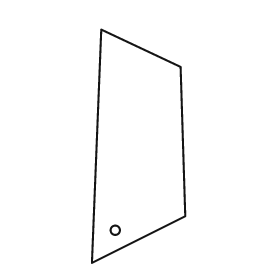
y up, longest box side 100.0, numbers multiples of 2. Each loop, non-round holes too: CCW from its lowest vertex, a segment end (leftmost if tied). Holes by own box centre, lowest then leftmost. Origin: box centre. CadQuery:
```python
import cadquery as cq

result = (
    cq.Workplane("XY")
    .moveTo(-20.0, -50.0)
    .lineTo(20.0, -30.0)
    .lineTo(18.0, 34.0)
    .lineTo(-16.0, 50.0)
    .close()
    .moveTo(-10.0, -36.0)
    .circle(2.0)
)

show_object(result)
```